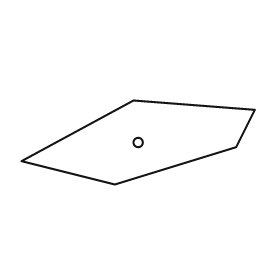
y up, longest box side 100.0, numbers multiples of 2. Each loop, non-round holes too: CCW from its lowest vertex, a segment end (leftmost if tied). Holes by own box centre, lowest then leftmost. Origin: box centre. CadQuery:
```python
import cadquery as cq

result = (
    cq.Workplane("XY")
    .moveTo(-10.0, -18.0)
    .lineTo(42.0, -2.0)
    .lineTo(50.0, 14.0)
    .lineTo(-2.0, 18.0)
    .lineTo(-50.0, -8.0)
    .close()
    .moveTo(0.0, 0.0)
    .circle(2.0)
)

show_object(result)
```